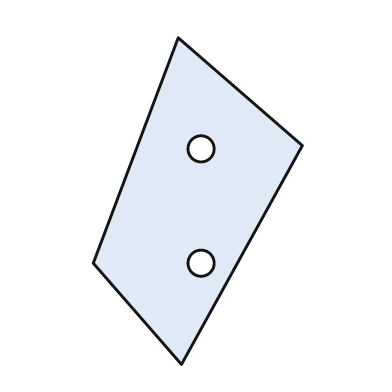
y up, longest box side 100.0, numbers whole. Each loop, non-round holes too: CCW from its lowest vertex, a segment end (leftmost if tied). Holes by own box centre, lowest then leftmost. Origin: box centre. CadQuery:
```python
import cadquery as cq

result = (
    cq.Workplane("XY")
    .moveTo(-5.0, -50.0)
    .lineTo(32.0, 17.0)
    .lineTo(-6.0, 50.0)
    .lineTo(-32.0, -19.0)
    .close()
    .moveTo(1.0, -19.0)
    .circle(4.0)
    .moveTo(1.0, 16.0)
    .circle(4.0)
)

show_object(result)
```